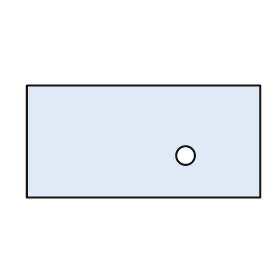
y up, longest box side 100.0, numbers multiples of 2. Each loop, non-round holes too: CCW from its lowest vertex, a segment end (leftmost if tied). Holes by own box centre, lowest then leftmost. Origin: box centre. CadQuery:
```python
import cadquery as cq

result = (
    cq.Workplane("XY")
    .moveTo(-50.0, -24.0)
    .lineTo(50.0, -24.0)
    .lineTo(50.0, 24.0)
    .lineTo(-50.0, 24.0)
    .close()
    .moveTo(18.0, -6.0)
    .circle(4.0)
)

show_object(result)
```